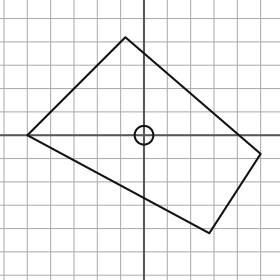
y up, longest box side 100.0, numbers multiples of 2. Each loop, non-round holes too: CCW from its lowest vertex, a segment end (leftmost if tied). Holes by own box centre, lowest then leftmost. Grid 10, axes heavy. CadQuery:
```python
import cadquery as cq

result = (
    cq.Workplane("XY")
    .moveTo(28.0, -42.0)
    .lineTo(50.0, -8.0)
    .lineTo(-8.0, 42.0)
    .lineTo(-50.0, 0.0)
    .close()
    .moveTo(0.0, 0.0)
    .circle(4.0)
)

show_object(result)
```